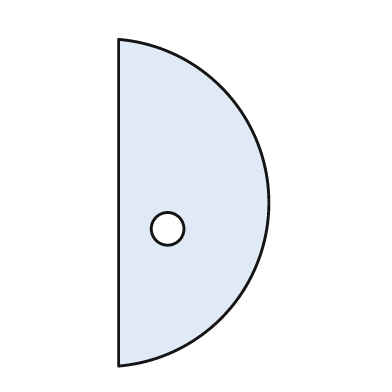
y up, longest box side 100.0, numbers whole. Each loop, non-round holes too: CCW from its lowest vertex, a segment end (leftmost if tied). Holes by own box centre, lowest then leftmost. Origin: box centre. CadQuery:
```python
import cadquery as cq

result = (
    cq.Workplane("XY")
    .moveTo(-23.0, -50.0)
    .threePointArc((23.0, 0.0), (-23.0, 50.0))
    .close()
    .moveTo(-8.0, -8.0)
    .circle(5.0)
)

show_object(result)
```